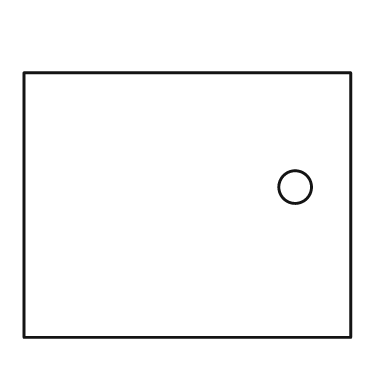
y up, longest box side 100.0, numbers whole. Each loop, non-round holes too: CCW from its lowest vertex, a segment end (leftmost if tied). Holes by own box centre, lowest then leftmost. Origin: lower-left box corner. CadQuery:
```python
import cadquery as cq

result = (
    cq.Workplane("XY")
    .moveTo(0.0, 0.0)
    .lineTo(100.0, 0.0)
    .lineTo(100.0, 81.0)
    .lineTo(0.0, 81.0)
    .close()
    .moveTo(83.0, 46.0)
    .circle(5.0)
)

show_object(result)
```